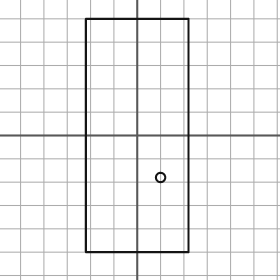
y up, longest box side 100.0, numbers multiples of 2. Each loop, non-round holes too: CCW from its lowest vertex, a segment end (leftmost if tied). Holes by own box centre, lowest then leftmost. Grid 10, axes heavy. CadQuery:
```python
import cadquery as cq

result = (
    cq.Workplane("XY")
    .moveTo(-22.0, -50.0)
    .lineTo(22.0, -50.0)
    .lineTo(22.0, 50.0)
    .lineTo(-22.0, 50.0)
    .close()
    .moveTo(10.0, -18.0)
    .circle(2.0)
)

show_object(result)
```